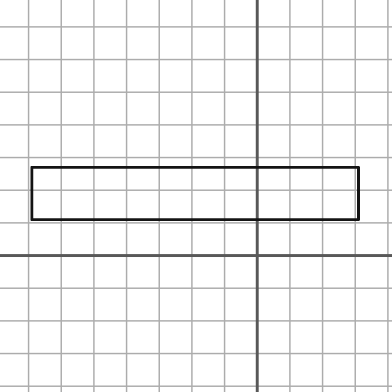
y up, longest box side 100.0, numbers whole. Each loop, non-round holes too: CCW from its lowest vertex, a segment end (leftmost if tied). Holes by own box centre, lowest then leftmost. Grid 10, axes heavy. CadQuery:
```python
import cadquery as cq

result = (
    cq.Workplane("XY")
    .moveTo(-69.0, 11.0)
    .lineTo(31.0, 11.0)
    .lineTo(31.0, 27.0)
    .lineTo(-69.0, 27.0)
    .close()
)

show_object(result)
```